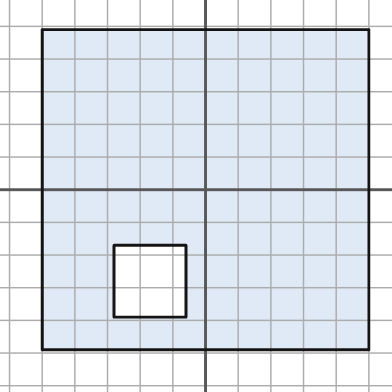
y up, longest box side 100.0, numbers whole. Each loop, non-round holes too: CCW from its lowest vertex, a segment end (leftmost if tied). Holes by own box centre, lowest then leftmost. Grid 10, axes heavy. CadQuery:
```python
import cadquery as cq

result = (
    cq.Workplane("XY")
    .moveTo(-50.0, -49.0)
    .lineTo(50.0, -49.0)
    .lineTo(50.0, 49.0)
    .lineTo(-50.0, 49.0)
    .close()
    .moveTo(-28.0, -39.0)
    .lineTo(-6.0, -39.0)
    .lineTo(-6.0, -17.0)
    .lineTo(-28.0, -17.0)
    .close()
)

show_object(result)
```